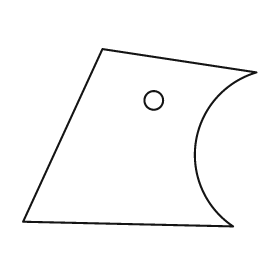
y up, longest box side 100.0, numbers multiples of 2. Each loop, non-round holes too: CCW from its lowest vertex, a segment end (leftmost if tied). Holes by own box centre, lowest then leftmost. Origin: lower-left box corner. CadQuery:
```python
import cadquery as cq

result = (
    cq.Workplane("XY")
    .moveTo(90.0, 0.0)
    .threePointArc((74.0, 36.0), (100.0, 66.0))
    .lineTo(34.0, 76.0)
    .lineTo(0.0, 2.0)
    .close()
    .moveTo(56.0, 54.0)
    .circle(4.0)
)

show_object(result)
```